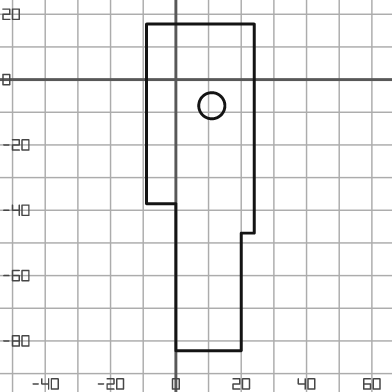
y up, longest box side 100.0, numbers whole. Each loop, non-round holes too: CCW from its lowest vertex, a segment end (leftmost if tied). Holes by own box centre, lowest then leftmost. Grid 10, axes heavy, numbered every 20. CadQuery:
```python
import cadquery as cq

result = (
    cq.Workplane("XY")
    .moveTo(0.0, -83.0)
    .lineTo(20.0, -83.0)
    .lineTo(20.0, -47.0)
    .lineTo(24.0, -47.0)
    .lineTo(24.0, 17.0)
    .lineTo(-9.0, 17.0)
    .lineTo(-9.0, -38.0)
    .lineTo(0.0, -38.0)
    .close()
    .moveTo(11.0, -8.0)
    .circle(4.0)
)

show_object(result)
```